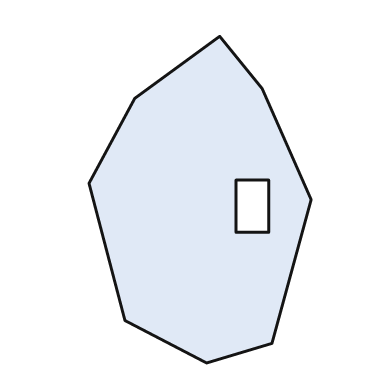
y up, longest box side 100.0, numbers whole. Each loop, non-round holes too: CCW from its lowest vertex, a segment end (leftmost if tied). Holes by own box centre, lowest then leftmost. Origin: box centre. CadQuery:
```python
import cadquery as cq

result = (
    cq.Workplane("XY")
    .moveTo(2.0, -50.0)
    .lineTo(22.0, -44.0)
    .lineTo(34.0, 0.0)
    .lineTo(19.0, 34.0)
    .lineTo(6.0, 50.0)
    .lineTo(-20.0, 31.0)
    .lineTo(-34.0, 5.0)
    .lineTo(-23.0, -37.0)
    .close()
    .moveTo(11.0, -10.0)
    .lineTo(21.0, -10.0)
    .lineTo(21.0, 6.0)
    .lineTo(11.0, 6.0)
    .close()
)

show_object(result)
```